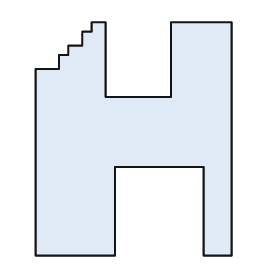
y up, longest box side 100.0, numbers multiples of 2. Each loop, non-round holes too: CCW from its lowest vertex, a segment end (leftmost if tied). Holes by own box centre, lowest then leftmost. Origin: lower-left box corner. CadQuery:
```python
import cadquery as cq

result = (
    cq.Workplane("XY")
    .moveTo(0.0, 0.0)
    .lineTo(34.0, 0.0)
    .lineTo(34.0, 38.0)
    .lineTo(72.0, 38.0)
    .lineTo(72.0, 0.0)
    .lineTo(84.0, 0.0)
    .lineTo(84.0, 100.0)
    .lineTo(58.0, 100.0)
    .lineTo(58.0, 68.0)
    .lineTo(30.0, 68.0)
    .lineTo(30.0, 100.0)
    .lineTo(24.0, 100.0)
    .lineTo(24.0, 96.0)
    .lineTo(20.0, 96.0)
    .lineTo(20.0, 90.0)
    .lineTo(14.0, 90.0)
    .lineTo(14.0, 86.0)
    .lineTo(10.0, 86.0)
    .lineTo(10.0, 80.0)
    .lineTo(0.0, 80.0)
    .close()
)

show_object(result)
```